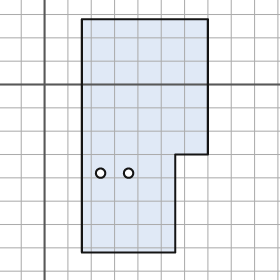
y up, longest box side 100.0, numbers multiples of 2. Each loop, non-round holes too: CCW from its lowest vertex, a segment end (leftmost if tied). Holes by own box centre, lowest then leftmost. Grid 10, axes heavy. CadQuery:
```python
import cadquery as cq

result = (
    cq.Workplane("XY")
    .moveTo(16.0, -72.0)
    .lineTo(56.0, -72.0)
    .lineTo(56.0, -30.0)
    .lineTo(70.0, -30.0)
    .lineTo(70.0, 28.0)
    .lineTo(16.0, 28.0)
    .close()
    .moveTo(24.0, -38.0)
    .circle(2.0)
    .moveTo(36.0, -38.0)
    .circle(2.0)
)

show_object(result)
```